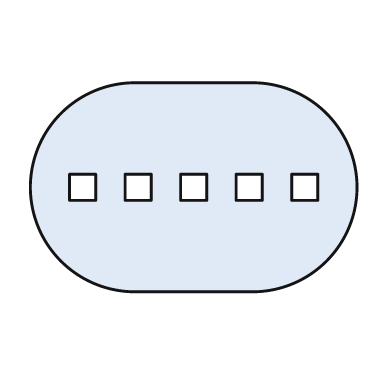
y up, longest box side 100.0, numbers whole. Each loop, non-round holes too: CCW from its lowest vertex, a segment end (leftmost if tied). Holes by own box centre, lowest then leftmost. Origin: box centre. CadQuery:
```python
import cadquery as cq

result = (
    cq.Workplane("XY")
    .moveTo(-18.0, -32.0)
    .lineTo(18.0, -32.0)
    .threePointArc((50.0, 0.0), (18.0, 32.0))
    .lineTo(-18.0, 32.0)
    .threePointArc((-50.0, 0.0), (-18.0, -32.0))
    .close()
    .moveTo(-38.0, -4.0)
    .lineTo(-30.0, -4.0)
    .lineTo(-30.0, 4.0)
    .lineTo(-38.0, 4.0)
    .close()
    .moveTo(-21.0, -4.0)
    .lineTo(-13.0, -4.0)
    .lineTo(-13.0, 4.0)
    .lineTo(-21.0, 4.0)
    .close()
    .moveTo(-4.0, -4.0)
    .lineTo(4.0, -4.0)
    .lineTo(4.0, 4.0)
    .lineTo(-4.0, 4.0)
    .close()
    .moveTo(13.0, -4.0)
    .lineTo(21.0, -4.0)
    .lineTo(21.0, 4.0)
    .lineTo(13.0, 4.0)
    .close()
    .moveTo(30.0, -4.0)
    .lineTo(38.0, -4.0)
    .lineTo(38.0, 4.0)
    .lineTo(30.0, 4.0)
    .close()
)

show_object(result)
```